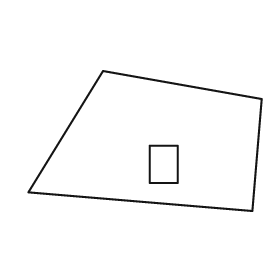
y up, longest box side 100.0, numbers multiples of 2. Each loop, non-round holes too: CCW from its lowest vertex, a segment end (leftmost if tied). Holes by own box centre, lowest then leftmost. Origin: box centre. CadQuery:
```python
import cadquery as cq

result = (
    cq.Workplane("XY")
    .moveTo(46.0, -30.0)
    .lineTo(50.0, 18.0)
    .lineTo(-18.0, 30.0)
    .lineTo(-50.0, -22.0)
    .close()
    .moveTo(2.0, -18.0)
    .lineTo(14.0, -18.0)
    .lineTo(14.0, -2.0)
    .lineTo(2.0, -2.0)
    .close()
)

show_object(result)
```